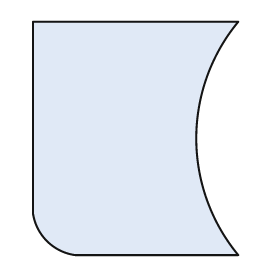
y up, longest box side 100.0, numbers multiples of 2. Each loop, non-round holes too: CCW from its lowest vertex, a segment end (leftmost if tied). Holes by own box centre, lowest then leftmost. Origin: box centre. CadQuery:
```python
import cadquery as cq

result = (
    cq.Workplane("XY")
    .moveTo(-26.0, -50.0)
    .lineTo(44.0, -50.0)
    .threePointArc((26.0, 0.0), (44.0, 50.0))
    .lineTo(-44.0, 50.0)
    .lineTo(-44.0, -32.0)
    .threePointArc((-38.0, -44.0), (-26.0, -50.0))
    .close()
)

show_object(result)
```